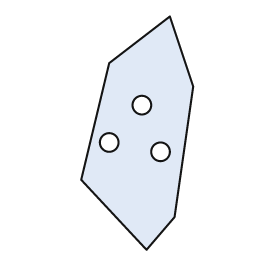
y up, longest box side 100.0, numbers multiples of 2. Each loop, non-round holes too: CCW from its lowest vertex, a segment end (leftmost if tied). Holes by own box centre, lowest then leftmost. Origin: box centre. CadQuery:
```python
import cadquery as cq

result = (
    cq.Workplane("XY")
    .moveTo(4.0, -50.0)
    .lineTo(16.0, -36.0)
    .lineTo(24.0, 20.0)
    .lineTo(14.0, 50.0)
    .lineTo(-12.0, 30.0)
    .lineTo(-24.0, -20.0)
    .close()
    .moveTo(10.0, -8.0)
    .circle(4.0)
    .moveTo(-12.0, -4.0)
    .circle(4.0)
    .moveTo(2.0, 12.0)
    .circle(4.0)
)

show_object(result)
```